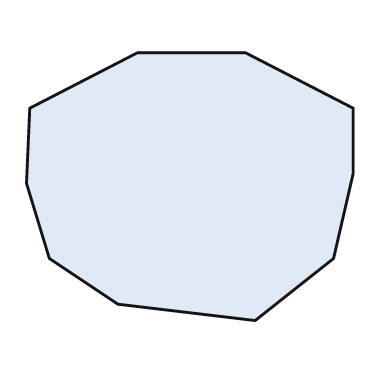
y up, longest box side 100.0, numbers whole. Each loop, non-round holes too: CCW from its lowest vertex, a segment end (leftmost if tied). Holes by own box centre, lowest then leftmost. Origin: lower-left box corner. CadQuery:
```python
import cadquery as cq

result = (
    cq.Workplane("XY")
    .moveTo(70.0, 0.0)
    .lineTo(94.0, 19.0)
    .lineTo(100.0, 45.0)
    .lineTo(100.0, 65.0)
    .lineTo(67.0, 82.0)
    .lineTo(34.0, 82.0)
    .lineTo(1.0, 65.0)
    .lineTo(0.0, 42.0)
    .lineTo(7.0, 19.0)
    .lineTo(28.0, 5.0)
    .close()
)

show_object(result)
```